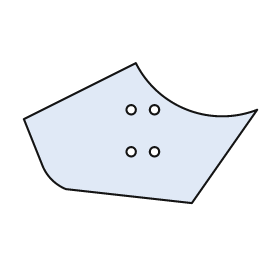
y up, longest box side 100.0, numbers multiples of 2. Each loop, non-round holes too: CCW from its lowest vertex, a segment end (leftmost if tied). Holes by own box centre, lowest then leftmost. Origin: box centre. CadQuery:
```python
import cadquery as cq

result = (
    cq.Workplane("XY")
    .moveTo(22.0, -30.0)
    .lineTo(50.0, 10.0)
    .threePointArc((20.0, 10.0), (-2.0, 30.0))
    .lineTo(-50.0, 6.0)
    .lineTo(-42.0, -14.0)
    .threePointArc((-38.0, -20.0), (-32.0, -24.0))
    .close()
    .moveTo(-4.0, -8.0)
    .circle(2.0)
    .moveTo(6.0, -8.0)
    .circle(2.0)
    .moveTo(-4.0, 10.0)
    .circle(2.0)
    .moveTo(6.0, 10.0)
    .circle(2.0)
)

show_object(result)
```